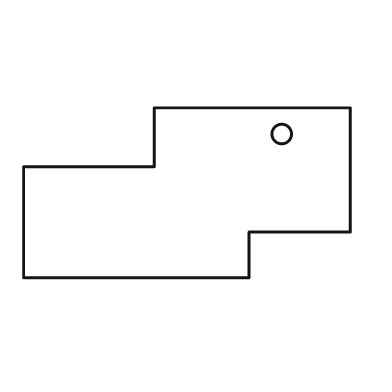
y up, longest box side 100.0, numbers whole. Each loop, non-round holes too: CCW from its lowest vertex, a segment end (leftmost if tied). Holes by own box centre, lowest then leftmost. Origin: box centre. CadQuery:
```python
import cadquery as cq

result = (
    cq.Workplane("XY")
    .moveTo(-50.0, -26.0)
    .lineTo(19.0, -26.0)
    .lineTo(19.0, -12.0)
    .lineTo(50.0, -12.0)
    .lineTo(50.0, 26.0)
    .lineTo(-10.0, 26.0)
    .lineTo(-10.0, 8.0)
    .lineTo(-50.0, 8.0)
    .close()
    .moveTo(29.0, 18.0)
    .circle(3.0)
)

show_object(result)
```